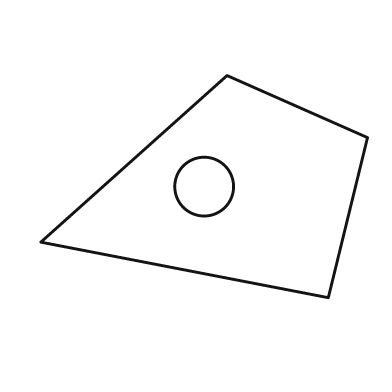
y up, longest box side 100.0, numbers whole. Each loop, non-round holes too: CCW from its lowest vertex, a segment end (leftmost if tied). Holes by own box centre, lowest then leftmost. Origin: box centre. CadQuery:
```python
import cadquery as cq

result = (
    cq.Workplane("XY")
    .moveTo(38.0, -34.0)
    .lineTo(50.0, 15.0)
    .lineTo(7.0, 34.0)
    .lineTo(-50.0, -17.0)
    .close()
    .moveTo(0.0, 0.0)
    .circle(9.0)
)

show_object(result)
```